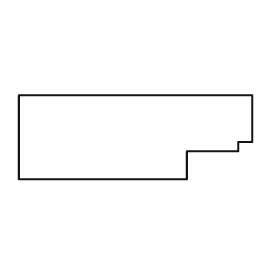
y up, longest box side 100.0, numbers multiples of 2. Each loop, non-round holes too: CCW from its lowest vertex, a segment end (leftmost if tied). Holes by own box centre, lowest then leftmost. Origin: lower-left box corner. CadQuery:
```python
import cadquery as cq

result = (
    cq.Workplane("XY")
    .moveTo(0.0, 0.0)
    .lineTo(72.0, 0.0)
    .lineTo(72.0, 12.0)
    .lineTo(94.0, 12.0)
    .lineTo(94.0, 16.0)
    .lineTo(100.0, 16.0)
    .lineTo(100.0, 36.0)
    .lineTo(0.0, 36.0)
    .close()
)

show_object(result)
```